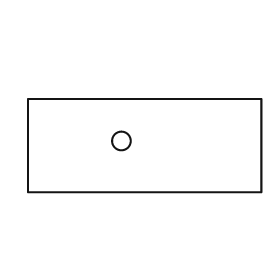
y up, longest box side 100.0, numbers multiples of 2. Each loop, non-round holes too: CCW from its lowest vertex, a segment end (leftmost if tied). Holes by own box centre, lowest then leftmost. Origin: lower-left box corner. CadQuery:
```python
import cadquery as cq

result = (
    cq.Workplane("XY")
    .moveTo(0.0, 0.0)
    .lineTo(100.0, 0.0)
    .lineTo(100.0, 40.0)
    .lineTo(0.0, 40.0)
    .close()
    .moveTo(40.0, 22.0)
    .circle(4.0)
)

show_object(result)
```